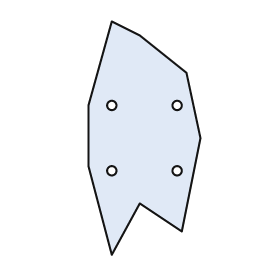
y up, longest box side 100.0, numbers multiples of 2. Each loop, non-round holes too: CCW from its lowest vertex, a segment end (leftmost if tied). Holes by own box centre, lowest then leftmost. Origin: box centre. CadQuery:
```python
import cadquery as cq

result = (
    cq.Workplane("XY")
    .moveTo(-14.0, -50.0)
    .lineTo(-2.0, -28.0)
    .lineTo(16.0, -40.0)
    .lineTo(24.0, 0.0)
    .lineTo(18.0, 28.0)
    .lineTo(-2.0, 44.0)
    .lineTo(-14.0, 50.0)
    .lineTo(-24.0, 14.0)
    .lineTo(-24.0, -12.0)
    .close()
    .moveTo(-14.0, -14.0)
    .circle(2.0)
    .moveTo(14.0, -14.0)
    .circle(2.0)
    .moveTo(-14.0, 14.0)
    .circle(2.0)
    .moveTo(14.0, 14.0)
    .circle(2.0)
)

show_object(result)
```